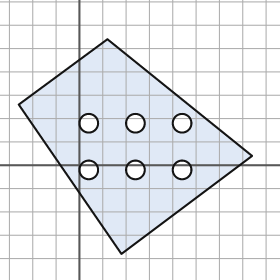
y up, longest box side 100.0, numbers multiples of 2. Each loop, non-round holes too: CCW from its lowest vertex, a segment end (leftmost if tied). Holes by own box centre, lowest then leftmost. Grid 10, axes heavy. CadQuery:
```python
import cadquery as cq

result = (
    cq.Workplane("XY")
    .moveTo(18.0, -38.0)
    .lineTo(74.0, 4.0)
    .lineTo(12.0, 54.0)
    .lineTo(-26.0, 26.0)
    .close()
    .moveTo(4.0, -2.0)
    .circle(4.0)
    .moveTo(24.0, -2.0)
    .circle(4.0)
    .moveTo(44.0, -2.0)
    .circle(4.0)
    .moveTo(4.0, 18.0)
    .circle(4.0)
    .moveTo(24.0, 18.0)
    .circle(4.0)
    .moveTo(44.0, 18.0)
    .circle(4.0)
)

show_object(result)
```